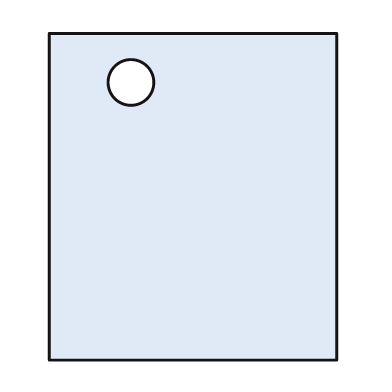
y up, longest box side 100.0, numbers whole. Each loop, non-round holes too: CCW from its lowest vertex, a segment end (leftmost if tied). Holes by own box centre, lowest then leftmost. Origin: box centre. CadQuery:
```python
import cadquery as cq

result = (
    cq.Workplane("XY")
    .moveTo(-44.0, -50.0)
    .lineTo(44.0, -50.0)
    .lineTo(44.0, 50.0)
    .lineTo(-44.0, 50.0)
    .close()
    .moveTo(-19.0, 35.0)
    .circle(7.0)
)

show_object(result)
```